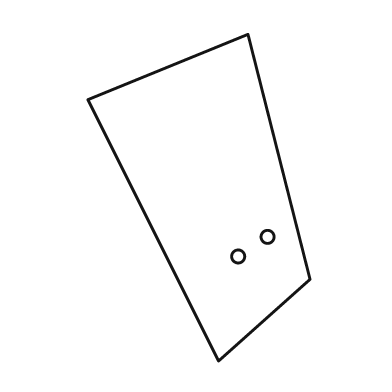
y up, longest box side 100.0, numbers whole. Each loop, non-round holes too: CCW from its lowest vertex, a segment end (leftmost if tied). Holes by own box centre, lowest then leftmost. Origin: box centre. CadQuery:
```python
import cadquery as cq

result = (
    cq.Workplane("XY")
    .moveTo(6.0, -50.0)
    .lineTo(34.0, -25.0)
    .lineTo(15.0, 50.0)
    .lineTo(-34.0, 30.0)
    .close()
    .moveTo(12.0, -18.0)
    .circle(2.0)
    .moveTo(21.0, -12.0)
    .circle(2.0)
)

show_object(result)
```